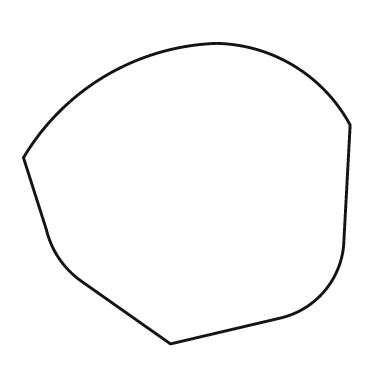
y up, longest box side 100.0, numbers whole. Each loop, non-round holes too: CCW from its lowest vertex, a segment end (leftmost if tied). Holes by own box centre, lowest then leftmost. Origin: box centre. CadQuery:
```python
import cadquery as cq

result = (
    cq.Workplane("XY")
    .moveTo(-5.0, -46.0)
    .lineTo(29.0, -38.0)
    .threePointArc((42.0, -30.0), (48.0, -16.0))
    .lineTo(50.0, 21.0)
    .threePointArc((33.0, 39.0), (9.0, 46.0))
    .threePointArc((-25.0, 36.0), (-50.0, 11.0))
    .lineTo(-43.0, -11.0)
    .threePointArc((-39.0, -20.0), (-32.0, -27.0))
    .close()
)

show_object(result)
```